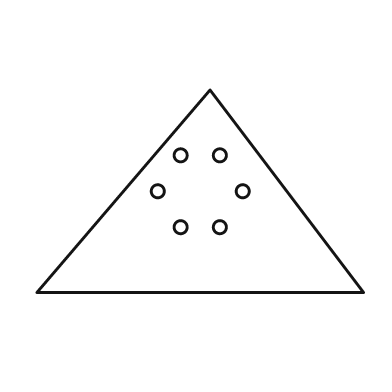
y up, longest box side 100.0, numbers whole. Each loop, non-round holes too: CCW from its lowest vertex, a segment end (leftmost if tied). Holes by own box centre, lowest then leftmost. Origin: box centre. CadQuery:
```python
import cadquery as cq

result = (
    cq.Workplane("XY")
    .moveTo(-50.0, -31.0)
    .lineTo(50.0, -31.0)
    .lineTo(3.0, 31.0)
    .close()
    .moveTo(-6.0, -11.0)
    .circle(2.0)
    .moveTo(6.0, -11.0)
    .circle(2.0)
    .moveTo(-13.0, 0.0)
    .circle(2.0)
    .moveTo(13.0, 0.0)
    .circle(2.0)
    .moveTo(-6.0, 11.0)
    .circle(2.0)
    .moveTo(6.0, 11.0)
    .circle(2.0)
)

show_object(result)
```